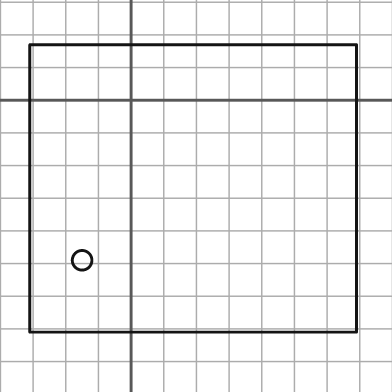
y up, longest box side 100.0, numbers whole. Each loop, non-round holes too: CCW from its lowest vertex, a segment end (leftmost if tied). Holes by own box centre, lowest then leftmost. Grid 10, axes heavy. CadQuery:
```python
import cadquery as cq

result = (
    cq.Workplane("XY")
    .moveTo(-31.0, -71.0)
    .lineTo(69.0, -71.0)
    .lineTo(69.0, 17.0)
    .lineTo(-31.0, 17.0)
    .close()
    .moveTo(-15.0, -49.0)
    .circle(3.0)
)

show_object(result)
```